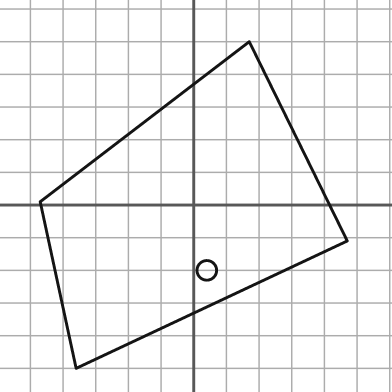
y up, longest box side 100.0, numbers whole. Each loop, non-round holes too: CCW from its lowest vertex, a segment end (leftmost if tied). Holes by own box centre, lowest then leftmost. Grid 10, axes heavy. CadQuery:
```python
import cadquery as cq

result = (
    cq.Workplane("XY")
    .moveTo(-36.0, -50.0)
    .lineTo(47.0, -11.0)
    .lineTo(17.0, 50.0)
    .lineTo(-47.0, 1.0)
    .close()
    .moveTo(4.0, -20.0)
    .circle(3.0)
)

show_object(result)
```